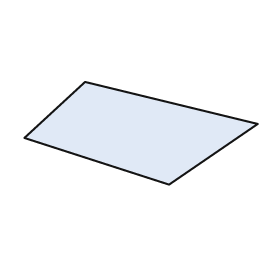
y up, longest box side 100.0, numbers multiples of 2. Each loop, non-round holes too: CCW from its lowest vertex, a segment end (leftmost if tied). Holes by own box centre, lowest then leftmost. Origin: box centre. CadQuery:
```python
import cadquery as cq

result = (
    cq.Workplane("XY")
    .moveTo(12.0, -22.0)
    .lineTo(50.0, 4.0)
    .lineTo(-24.0, 22.0)
    .lineTo(-50.0, -2.0)
    .close()
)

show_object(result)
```